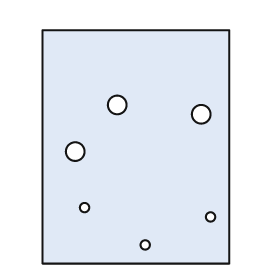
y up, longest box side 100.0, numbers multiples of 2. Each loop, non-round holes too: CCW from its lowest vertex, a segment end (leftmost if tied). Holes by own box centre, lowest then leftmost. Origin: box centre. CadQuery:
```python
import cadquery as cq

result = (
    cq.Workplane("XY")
    .moveTo(-40.0, -50.0)
    .lineTo(40.0, -50.0)
    .lineTo(40.0, 50.0)
    .lineTo(-40.0, 50.0)
    .close()
    .moveTo(4.0, -42.0)
    .circle(2.0)
    .moveTo(32.0, -30.0)
    .circle(2.0)
    .moveTo(-22.0, -26.0)
    .circle(2.0)
    .moveTo(-26.0, -2.0)
    .circle(4.0)
    .moveTo(28.0, 14.0)
    .circle(4.0)
    .moveTo(-8.0, 18.0)
    .circle(4.0)
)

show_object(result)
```